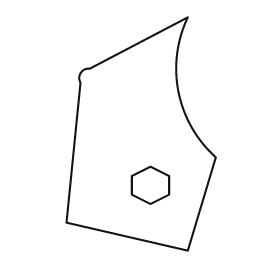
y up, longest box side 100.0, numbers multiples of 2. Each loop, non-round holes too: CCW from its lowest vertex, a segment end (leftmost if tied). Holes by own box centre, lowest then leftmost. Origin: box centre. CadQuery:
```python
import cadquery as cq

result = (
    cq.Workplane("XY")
    .moveTo(20.0, -50.0)
    .lineTo(32.0, -10.0)
    .threePointArc((16.0, 18.0), (20.0, 50.0))
    .lineTo(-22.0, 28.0)
    .threePointArc((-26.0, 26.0), (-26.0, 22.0))
    .lineTo(-32.0, -38.0)
    .close()
    .moveTo(4.0, -30.0)
    .lineTo(12.0, -26.0)
    .lineTo(12.0, -18.0)
    .lineTo(4.0, -14.0)
    .lineTo(-4.0, -18.0)
    .lineTo(-4.0, -26.0)
    .close()
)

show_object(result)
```